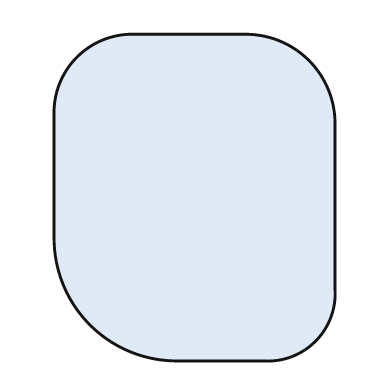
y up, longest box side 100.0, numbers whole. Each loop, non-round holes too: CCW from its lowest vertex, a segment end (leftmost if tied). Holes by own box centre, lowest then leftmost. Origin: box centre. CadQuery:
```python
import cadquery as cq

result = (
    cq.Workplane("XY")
    .moveTo(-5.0, -50.0)
    .lineTo(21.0, -50.0)
    .threePointArc((37.0, -44.0), (43.0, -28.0))
    .lineTo(43.0, 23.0)
    .threePointArc((35.0, 42.0), (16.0, 50.0))
    .lineTo(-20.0, 50.0)
    .threePointArc((-36.0, 43.0), (-43.0, 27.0))
    .lineTo(-43.0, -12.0)
    .threePointArc((-32.0, -39.0), (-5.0, -50.0))
    .close()
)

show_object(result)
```